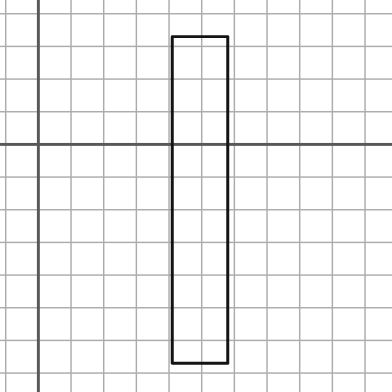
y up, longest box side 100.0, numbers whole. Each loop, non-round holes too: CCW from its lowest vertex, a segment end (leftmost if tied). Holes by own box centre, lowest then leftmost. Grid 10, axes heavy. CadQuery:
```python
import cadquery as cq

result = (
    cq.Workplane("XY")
    .moveTo(41.0, -67.0)
    .lineTo(58.0, -67.0)
    .lineTo(58.0, 33.0)
    .lineTo(41.0, 33.0)
    .close()
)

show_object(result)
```